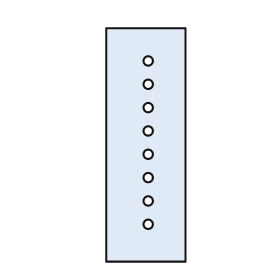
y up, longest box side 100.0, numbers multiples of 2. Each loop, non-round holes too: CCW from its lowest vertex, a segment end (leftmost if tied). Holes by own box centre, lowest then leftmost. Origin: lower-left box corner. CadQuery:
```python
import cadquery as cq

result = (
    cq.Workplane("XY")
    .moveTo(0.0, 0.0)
    .lineTo(34.0, 0.0)
    .lineTo(34.0, 100.0)
    .lineTo(0.0, 100.0)
    .close()
    .moveTo(18.0, 16.0)
    .circle(2.0)
    .moveTo(18.0, 26.0)
    .circle(2.0)
    .moveTo(18.0, 36.0)
    .circle(2.0)
    .moveTo(18.0, 46.0)
    .circle(2.0)
    .moveTo(18.0, 56.0)
    .circle(2.0)
    .moveTo(18.0, 66.0)
    .circle(2.0)
    .moveTo(18.0, 76.0)
    .circle(2.0)
    .moveTo(18.0, 86.0)
    .circle(2.0)
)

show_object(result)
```